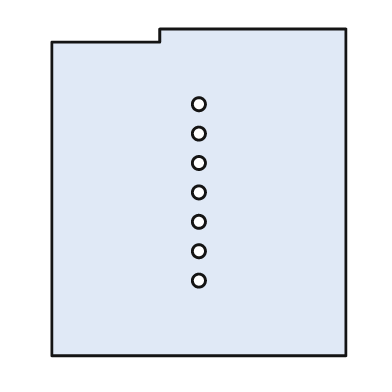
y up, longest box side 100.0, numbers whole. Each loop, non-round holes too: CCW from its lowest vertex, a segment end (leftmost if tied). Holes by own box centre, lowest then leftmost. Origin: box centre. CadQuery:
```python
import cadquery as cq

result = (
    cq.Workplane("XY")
    .moveTo(-45.0, -50.0)
    .lineTo(45.0, -50.0)
    .lineTo(45.0, 50.0)
    .lineTo(-12.0, 50.0)
    .lineTo(-12.0, 46.0)
    .lineTo(-45.0, 46.0)
    .close()
    .moveTo(0.0, -27.0)
    .circle(2.0)
    .moveTo(0.0, -18.0)
    .circle(2.0)
    .moveTo(0.0, -9.0)
    .circle(2.0)
    .moveTo(0.0, 0.0)
    .circle(2.0)
    .moveTo(0.0, 9.0)
    .circle(2.0)
    .moveTo(0.0, 18.0)
    .circle(2.0)
    .moveTo(0.0, 27.0)
    .circle(2.0)
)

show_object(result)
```